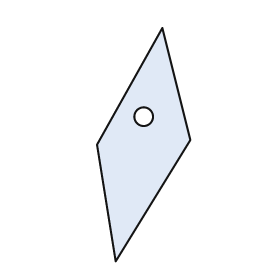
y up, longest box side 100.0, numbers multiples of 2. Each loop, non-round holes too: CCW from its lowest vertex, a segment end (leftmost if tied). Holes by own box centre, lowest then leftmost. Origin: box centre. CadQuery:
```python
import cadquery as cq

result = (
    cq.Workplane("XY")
    .moveTo(-12.0, -50.0)
    .lineTo(20.0, 2.0)
    .lineTo(8.0, 50.0)
    .lineTo(-20.0, 0.0)
    .close()
    .moveTo(0.0, 12.0)
    .circle(4.0)
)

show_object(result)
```